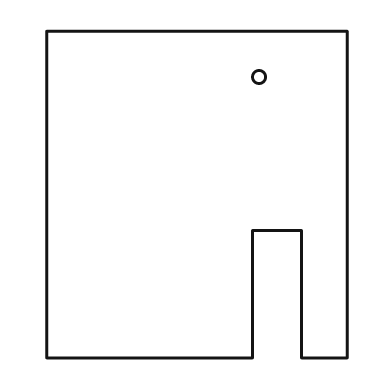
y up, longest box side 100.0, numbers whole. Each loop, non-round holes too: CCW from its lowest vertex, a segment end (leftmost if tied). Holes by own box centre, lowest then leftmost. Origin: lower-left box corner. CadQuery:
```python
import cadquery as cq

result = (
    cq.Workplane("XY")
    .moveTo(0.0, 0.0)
    .lineTo(63.0, 0.0)
    .lineTo(63.0, 39.0)
    .lineTo(78.0, 39.0)
    .lineTo(78.0, 0.0)
    .lineTo(92.0, 0.0)
    .lineTo(92.0, 100.0)
    .lineTo(0.0, 100.0)
    .close()
    .moveTo(65.0, 86.0)
    .circle(2.0)
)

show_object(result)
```